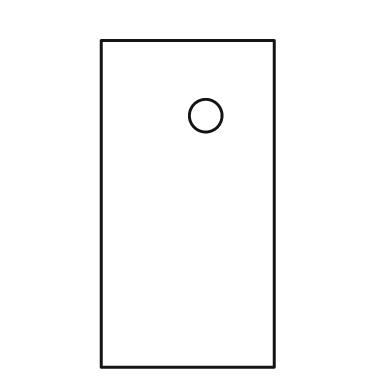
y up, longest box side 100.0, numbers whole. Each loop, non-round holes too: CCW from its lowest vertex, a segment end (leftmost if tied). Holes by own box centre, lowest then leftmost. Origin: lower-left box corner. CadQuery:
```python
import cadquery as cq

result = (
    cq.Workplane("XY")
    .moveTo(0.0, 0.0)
    .lineTo(53.0, 0.0)
    .lineTo(53.0, 100.0)
    .lineTo(0.0, 100.0)
    .close()
    .moveTo(32.0, 77.0)
    .circle(5.0)
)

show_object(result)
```